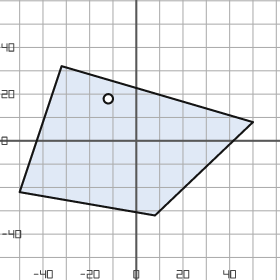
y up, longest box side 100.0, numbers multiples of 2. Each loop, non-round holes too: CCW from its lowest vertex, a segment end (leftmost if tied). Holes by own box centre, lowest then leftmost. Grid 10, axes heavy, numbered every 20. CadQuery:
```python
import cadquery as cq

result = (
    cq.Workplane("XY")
    .moveTo(8.0, -32.0)
    .lineTo(50.0, 8.0)
    .lineTo(-32.0, 32.0)
    .lineTo(-50.0, -22.0)
    .close()
    .moveTo(-12.0, 18.0)
    .circle(2.0)
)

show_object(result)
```